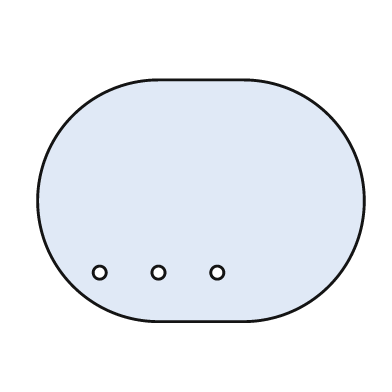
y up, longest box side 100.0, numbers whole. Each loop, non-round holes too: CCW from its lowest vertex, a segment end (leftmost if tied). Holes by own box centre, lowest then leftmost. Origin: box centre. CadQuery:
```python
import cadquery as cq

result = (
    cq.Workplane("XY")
    .moveTo(-13.0, -37.0)
    .lineTo(13.0, -37.0)
    .threePointArc((50.0, 0.0), (13.0, 37.0))
    .lineTo(-13.0, 37.0)
    .threePointArc((-50.0, 0.0), (-13.0, -37.0))
    .close()
    .moveTo(-31.0, -22.0)
    .circle(2.0)
    .moveTo(-13.0, -22.0)
    .circle(2.0)
    .moveTo(5.0, -22.0)
    .circle(2.0)
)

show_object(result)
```